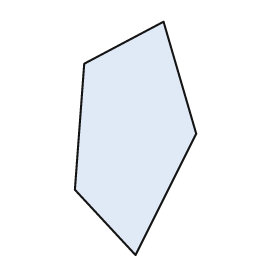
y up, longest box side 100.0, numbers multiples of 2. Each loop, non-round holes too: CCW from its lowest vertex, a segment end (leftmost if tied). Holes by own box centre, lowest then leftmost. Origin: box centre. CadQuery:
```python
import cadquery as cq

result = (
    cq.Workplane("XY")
    .moveTo(0.0, -50.0)
    .lineTo(26.0, 2.0)
    .lineTo(12.0, 50.0)
    .lineTo(-22.0, 32.0)
    .lineTo(-26.0, -22.0)
    .close()
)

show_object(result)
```